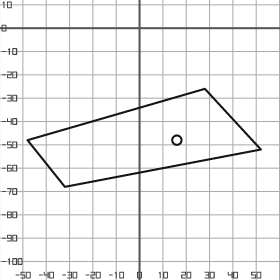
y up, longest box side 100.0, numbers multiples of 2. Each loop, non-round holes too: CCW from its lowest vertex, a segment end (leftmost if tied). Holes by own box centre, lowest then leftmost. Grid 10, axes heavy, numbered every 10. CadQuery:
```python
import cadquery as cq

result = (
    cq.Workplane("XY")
    .moveTo(-32.0, -68.0)
    .lineTo(52.0, -52.0)
    .lineTo(28.0, -26.0)
    .lineTo(-48.0, -48.0)
    .close()
    .moveTo(16.0, -48.0)
    .circle(2.0)
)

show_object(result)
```